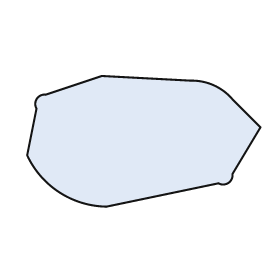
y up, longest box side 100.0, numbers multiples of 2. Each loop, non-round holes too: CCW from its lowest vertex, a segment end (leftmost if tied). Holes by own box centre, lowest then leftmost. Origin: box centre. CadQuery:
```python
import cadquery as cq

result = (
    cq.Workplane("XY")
    .moveTo(-16.0, -28.0)
    .lineTo(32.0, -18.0)
    .threePointArc((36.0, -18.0), (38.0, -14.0))
    .lineTo(50.0, 6.0)
    .lineTo(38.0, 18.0)
    .threePointArc((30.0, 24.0), (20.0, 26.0))
    .lineTo(-18.0, 28.0)
    .lineTo(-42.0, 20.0)
    .threePointArc((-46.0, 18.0), (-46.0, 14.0))
    .lineTo(-50.0, -6.0)
    .threePointArc((-36.0, -22.0), (-16.0, -28.0))
    .close()
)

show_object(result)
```